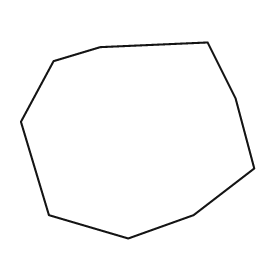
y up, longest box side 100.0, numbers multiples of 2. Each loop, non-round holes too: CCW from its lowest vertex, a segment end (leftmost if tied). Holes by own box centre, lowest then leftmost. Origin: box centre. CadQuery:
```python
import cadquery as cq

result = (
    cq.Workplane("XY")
    .moveTo(-4.0, -42.0)
    .lineTo(24.0, -32.0)
    .lineTo(50.0, -12.0)
    .lineTo(42.0, 18.0)
    .lineTo(30.0, 42.0)
    .lineTo(-16.0, 40.0)
    .lineTo(-36.0, 34.0)
    .lineTo(-50.0, 8.0)
    .lineTo(-38.0, -32.0)
    .close()
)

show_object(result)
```